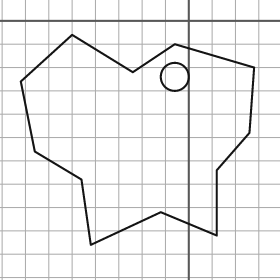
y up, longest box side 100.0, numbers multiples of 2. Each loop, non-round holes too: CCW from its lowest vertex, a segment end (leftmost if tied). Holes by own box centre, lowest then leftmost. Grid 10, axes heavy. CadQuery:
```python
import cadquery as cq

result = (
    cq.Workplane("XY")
    .moveTo(-42.0, -96.0)
    .lineTo(-12.0, -82.0)
    .lineTo(12.0, -92.0)
    .lineTo(12.0, -64.0)
    .lineTo(26.0, -48.0)
    .lineTo(28.0, -20.0)
    .lineTo(-6.0, -10.0)
    .lineTo(-24.0, -22.0)
    .lineTo(-50.0, -6.0)
    .lineTo(-72.0, -26.0)
    .lineTo(-66.0, -56.0)
    .lineTo(-46.0, -68.0)
    .close()
    .moveTo(-6.0, -24.0)
    .circle(6.0)
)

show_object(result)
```